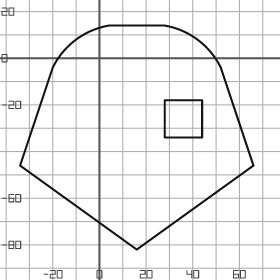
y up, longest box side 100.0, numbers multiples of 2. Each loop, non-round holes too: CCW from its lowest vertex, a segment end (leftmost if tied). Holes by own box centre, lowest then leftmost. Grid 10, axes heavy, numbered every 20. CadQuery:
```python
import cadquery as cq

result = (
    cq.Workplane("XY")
    .moveTo(16.0, -82.0)
    .lineTo(66.0, -46.0)
    .lineTo(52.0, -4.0)
    .threePointArc((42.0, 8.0), (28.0, 14.0))
    .lineTo(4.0, 14.0)
    .threePointArc((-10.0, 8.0), (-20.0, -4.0))
    .lineTo(-34.0, -46.0)
    .close()
    .moveTo(28.0, -34.0)
    .lineTo(44.0, -34.0)
    .lineTo(44.0, -18.0)
    .lineTo(28.0, -18.0)
    .close()
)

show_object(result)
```